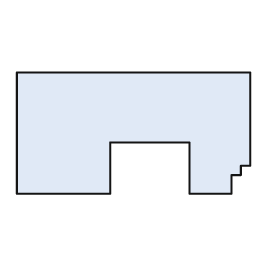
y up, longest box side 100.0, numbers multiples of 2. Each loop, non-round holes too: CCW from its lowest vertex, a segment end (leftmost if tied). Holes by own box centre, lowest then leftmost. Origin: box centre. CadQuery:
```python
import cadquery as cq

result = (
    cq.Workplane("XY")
    .moveTo(-50.0, -26.0)
    .lineTo(-10.0, -26.0)
    .lineTo(-10.0, -4.0)
    .lineTo(24.0, -4.0)
    .lineTo(24.0, -26.0)
    .lineTo(42.0, -26.0)
    .lineTo(42.0, -18.0)
    .lineTo(46.0, -18.0)
    .lineTo(46.0, -14.0)
    .lineTo(50.0, -14.0)
    .lineTo(50.0, 26.0)
    .lineTo(-50.0, 26.0)
    .close()
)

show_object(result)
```